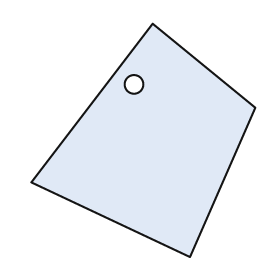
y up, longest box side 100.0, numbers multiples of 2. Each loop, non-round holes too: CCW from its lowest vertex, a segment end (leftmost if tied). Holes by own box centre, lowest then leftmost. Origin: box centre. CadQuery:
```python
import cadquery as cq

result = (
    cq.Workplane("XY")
    .moveTo(20.0, -50.0)
    .lineTo(48.0, 14.0)
    .lineTo(4.0, 50.0)
    .lineTo(-48.0, -18.0)
    .close()
    .moveTo(-4.0, 24.0)
    .circle(4.0)
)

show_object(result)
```